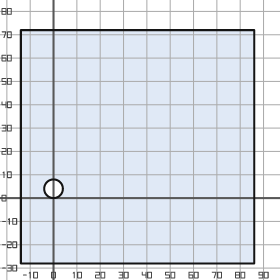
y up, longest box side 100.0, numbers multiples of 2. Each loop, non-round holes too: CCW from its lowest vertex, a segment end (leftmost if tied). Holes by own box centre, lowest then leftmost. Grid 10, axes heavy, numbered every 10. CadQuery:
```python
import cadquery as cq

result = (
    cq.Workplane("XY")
    .moveTo(-14.0, -28.0)
    .lineTo(86.0, -28.0)
    .lineTo(86.0, 72.0)
    .lineTo(-14.0, 72.0)
    .close()
    .moveTo(0.0, 4.0)
    .circle(4.0)
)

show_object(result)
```